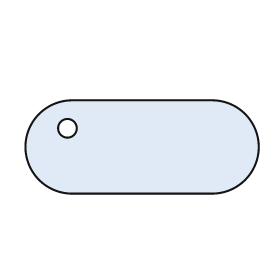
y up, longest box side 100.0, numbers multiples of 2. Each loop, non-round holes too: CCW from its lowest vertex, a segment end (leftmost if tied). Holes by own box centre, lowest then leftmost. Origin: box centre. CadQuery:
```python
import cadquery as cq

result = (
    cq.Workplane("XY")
    .moveTo(-30.0, -20.0)
    .lineTo(30.0, -20.0)
    .threePointArc((50.0, 0.0), (30.0, 20.0))
    .lineTo(-30.0, 20.0)
    .threePointArc((-50.0, 0.0), (-30.0, -20.0))
    .close()
    .moveTo(-32.0, 8.0)
    .circle(4.0)
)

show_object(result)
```